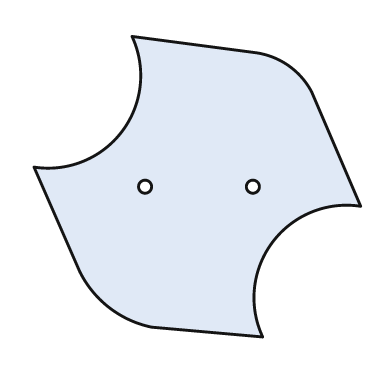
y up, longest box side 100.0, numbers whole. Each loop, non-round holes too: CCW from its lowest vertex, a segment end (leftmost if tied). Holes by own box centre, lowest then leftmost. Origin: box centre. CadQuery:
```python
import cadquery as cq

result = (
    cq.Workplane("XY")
    .moveTo(20.0, -46.0)
    .threePointArc((23.0, -17.0), (50.0, -6.0))
    .lineTo(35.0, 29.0)
    .threePointArc((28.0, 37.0), (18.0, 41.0))
    .lineTo(-20.0, 46.0)
    .threePointArc((-23.0, 17.0), (-50.0, 6.0))
    .lineTo(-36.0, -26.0)
    .threePointArc((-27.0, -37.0), (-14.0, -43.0))
    .close()
    .moveTo(-16.0, 0.0)
    .circle(2.0)
    .moveTo(17.0, 0.0)
    .circle(2.0)
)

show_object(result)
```